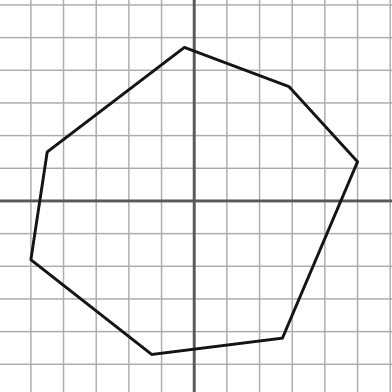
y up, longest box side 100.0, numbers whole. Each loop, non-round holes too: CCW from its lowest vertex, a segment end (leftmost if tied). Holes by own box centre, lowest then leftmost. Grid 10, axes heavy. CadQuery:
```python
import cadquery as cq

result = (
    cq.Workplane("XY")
    .moveTo(-13.0, -47.0)
    .lineTo(27.0, -42.0)
    .lineTo(50.0, 12.0)
    .lineTo(29.0, 35.0)
    .lineTo(-3.0, 47.0)
    .lineTo(-45.0, 15.0)
    .lineTo(-50.0, -18.0)
    .close()
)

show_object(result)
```